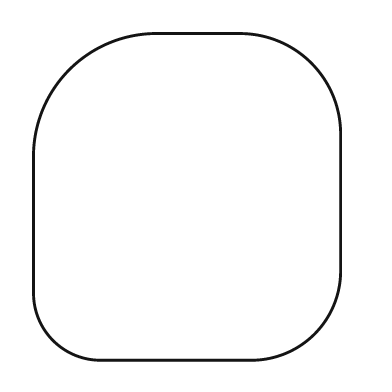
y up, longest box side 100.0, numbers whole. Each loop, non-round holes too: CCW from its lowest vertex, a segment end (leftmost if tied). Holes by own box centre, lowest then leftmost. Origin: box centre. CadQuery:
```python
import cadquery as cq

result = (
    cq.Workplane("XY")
    .moveTo(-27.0, -50.0)
    .lineTo(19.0, -50.0)
    .threePointArc((39.0, -42.0), (47.0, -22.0))
    .lineTo(47.0, 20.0)
    .threePointArc((38.0, 41.0), (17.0, 50.0))
    .lineTo(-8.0, 50.0)
    .threePointArc((-36.0, 39.0), (-47.0, 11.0))
    .lineTo(-47.0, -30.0)
    .threePointArc((-41.0, -44.0), (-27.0, -50.0))
    .close()
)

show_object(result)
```